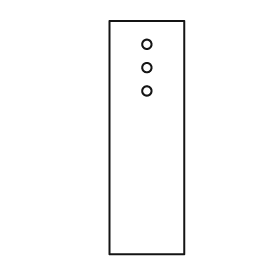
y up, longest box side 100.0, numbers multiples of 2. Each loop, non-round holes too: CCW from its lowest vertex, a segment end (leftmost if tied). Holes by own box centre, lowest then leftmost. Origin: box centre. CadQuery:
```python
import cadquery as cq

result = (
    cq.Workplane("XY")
    .moveTo(-16.0, -50.0)
    .lineTo(16.0, -50.0)
    .lineTo(16.0, 50.0)
    .lineTo(-16.0, 50.0)
    .close()
    .moveTo(0.0, 20.0)
    .circle(2.0)
    .moveTo(0.0, 30.0)
    .circle(2.0)
    .moveTo(0.0, 40.0)
    .circle(2.0)
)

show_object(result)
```